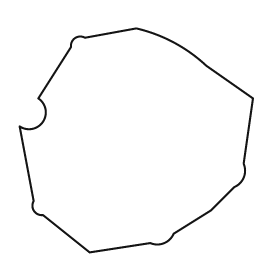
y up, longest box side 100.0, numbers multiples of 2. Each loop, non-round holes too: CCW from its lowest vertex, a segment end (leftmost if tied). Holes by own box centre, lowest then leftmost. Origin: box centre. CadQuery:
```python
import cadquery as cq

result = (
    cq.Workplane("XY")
    .moveTo(-20.0, -48.0)
    .lineTo(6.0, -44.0)
    .threePointArc((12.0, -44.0), (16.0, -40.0))
    .lineTo(32.0, -30.0)
    .lineTo(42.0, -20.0)
    .threePointArc((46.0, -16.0), (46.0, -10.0))
    .lineTo(50.0, 18.0)
    .lineTo(30.0, 32.0)
    .threePointArc((16.0, 42.0), (0.0, 48.0))
    .lineTo(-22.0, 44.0)
    .threePointArc((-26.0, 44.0), (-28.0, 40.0))
    .lineTo(-42.0, 18.0)
    .threePointArc((-40.0, 8.0), (-50.0, 6.0))
    .lineTo(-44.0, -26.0)
    .threePointArc((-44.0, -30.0), (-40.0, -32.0))
    .close()
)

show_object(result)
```